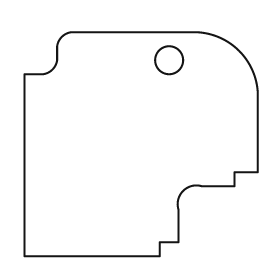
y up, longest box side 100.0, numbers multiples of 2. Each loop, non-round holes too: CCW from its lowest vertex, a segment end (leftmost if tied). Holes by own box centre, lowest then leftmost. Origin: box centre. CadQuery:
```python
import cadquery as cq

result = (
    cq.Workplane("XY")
    .moveTo(-50.0, -48.0)
    .lineTo(8.0, -48.0)
    .lineTo(8.0, -42.0)
    .lineTo(16.0, -42.0)
    .lineTo(16.0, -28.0)
    .threePointArc((18.0, -20.0), (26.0, -18.0))
    .lineTo(40.0, -18.0)
    .lineTo(40.0, -12.0)
    .lineTo(50.0, -12.0)
    .lineTo(50.0, 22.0)
    .threePointArc((42.0, 40.0), (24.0, 48.0))
    .lineTo(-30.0, 48.0)
    .threePointArc((-34.0, 46.0), (-36.0, 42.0))
    .lineTo(-36.0, 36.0)
    .threePointArc((-38.0, 32.0), (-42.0, 30.0))
    .lineTo(-50.0, 30.0)
    .close()
    .moveTo(12.0, 36.0)
    .circle(6.0)
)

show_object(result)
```